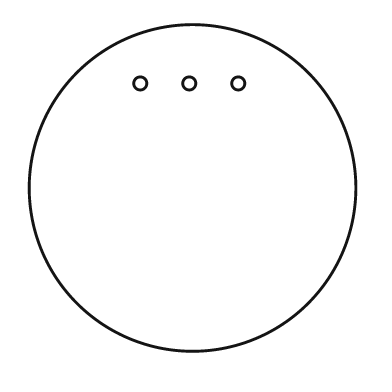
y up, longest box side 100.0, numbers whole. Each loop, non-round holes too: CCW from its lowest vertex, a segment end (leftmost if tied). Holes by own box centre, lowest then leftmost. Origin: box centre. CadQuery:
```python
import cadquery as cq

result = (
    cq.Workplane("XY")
    .moveTo(0.0, 0.0)
    .circle(50.0)
    .moveTo(-16.0, 32.0)
    .circle(2.0)
    .moveTo(-1.0, 32.0)
    .circle(2.0)
    .moveTo(14.0, 32.0)
    .circle(2.0)
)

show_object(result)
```